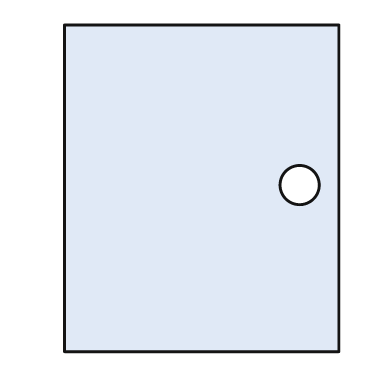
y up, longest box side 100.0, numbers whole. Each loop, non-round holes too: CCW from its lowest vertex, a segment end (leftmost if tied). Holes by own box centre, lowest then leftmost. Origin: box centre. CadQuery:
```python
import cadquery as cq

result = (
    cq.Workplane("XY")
    .moveTo(-42.0, -50.0)
    .lineTo(42.0, -50.0)
    .lineTo(42.0, 50.0)
    .lineTo(-42.0, 50.0)
    .close()
    .moveTo(30.0, 1.0)
    .circle(6.0)
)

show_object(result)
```